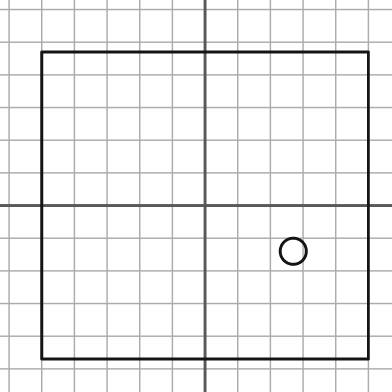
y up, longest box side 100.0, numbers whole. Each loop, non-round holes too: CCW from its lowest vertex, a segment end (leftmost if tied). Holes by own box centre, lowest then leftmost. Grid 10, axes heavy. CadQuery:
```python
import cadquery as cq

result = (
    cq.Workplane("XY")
    .moveTo(-50.0, -47.0)
    .lineTo(50.0, -47.0)
    .lineTo(50.0, 47.0)
    .lineTo(-50.0, 47.0)
    .close()
    .moveTo(27.0, -14.0)
    .circle(4.0)
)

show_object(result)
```